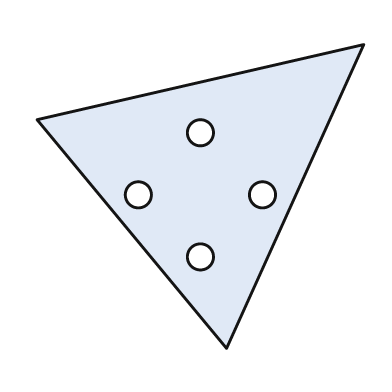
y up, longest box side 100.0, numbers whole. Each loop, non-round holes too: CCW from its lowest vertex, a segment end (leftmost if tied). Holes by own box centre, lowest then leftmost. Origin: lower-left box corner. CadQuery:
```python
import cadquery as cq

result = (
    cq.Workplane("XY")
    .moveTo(58.0, 0.0)
    .lineTo(100.0, 93.0)
    .lineTo(0.0, 70.0)
    .close()
    .moveTo(50.0, 28.0)
    .circle(4.0)
    .moveTo(31.0, 47.0)
    .circle(4.0)
    .moveTo(69.0, 47.0)
    .circle(4.0)
    .moveTo(50.0, 66.0)
    .circle(4.0)
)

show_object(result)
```